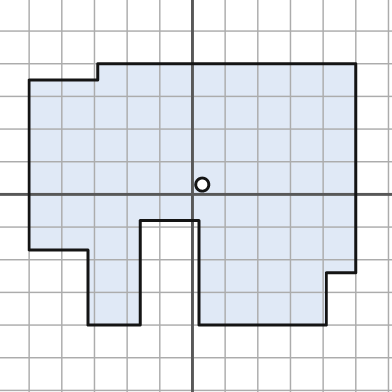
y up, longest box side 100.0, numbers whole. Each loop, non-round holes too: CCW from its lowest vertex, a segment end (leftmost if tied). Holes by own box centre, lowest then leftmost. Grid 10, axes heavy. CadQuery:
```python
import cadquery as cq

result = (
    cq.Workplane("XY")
    .moveTo(-32.0, -40.0)
    .lineTo(-16.0, -40.0)
    .lineTo(-16.0, -8.0)
    .lineTo(2.0, -8.0)
    .lineTo(2.0, -40.0)
    .lineTo(41.0, -40.0)
    .lineTo(41.0, -24.0)
    .lineTo(50.0, -24.0)
    .lineTo(50.0, 40.0)
    .lineTo(-29.0, 40.0)
    .lineTo(-29.0, 35.0)
    .lineTo(-50.0, 35.0)
    .lineTo(-50.0, -17.0)
    .lineTo(-32.0, -17.0)
    .close()
    .moveTo(3.0, 3.0)
    .circle(2.0)
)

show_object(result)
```